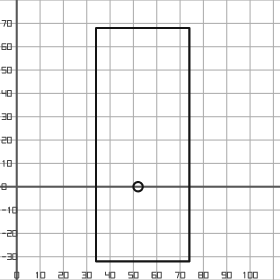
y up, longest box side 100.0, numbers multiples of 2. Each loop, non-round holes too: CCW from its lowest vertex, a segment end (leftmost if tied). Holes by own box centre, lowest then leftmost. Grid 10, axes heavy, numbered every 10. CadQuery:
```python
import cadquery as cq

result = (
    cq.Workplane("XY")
    .moveTo(34.0, -32.0)
    .lineTo(74.0, -32.0)
    .lineTo(74.0, 68.0)
    .lineTo(34.0, 68.0)
    .close()
    .moveTo(52.0, 0.0)
    .circle(2.0)
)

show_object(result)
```